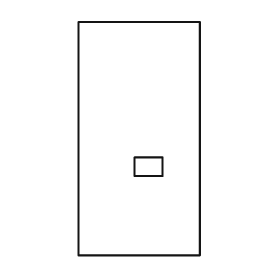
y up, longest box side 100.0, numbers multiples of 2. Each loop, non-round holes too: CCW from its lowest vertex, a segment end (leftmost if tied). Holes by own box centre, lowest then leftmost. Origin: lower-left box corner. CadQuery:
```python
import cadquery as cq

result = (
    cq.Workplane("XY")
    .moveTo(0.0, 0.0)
    .lineTo(52.0, 0.0)
    .lineTo(52.0, 100.0)
    .lineTo(0.0, 100.0)
    .close()
    .moveTo(24.0, 34.0)
    .lineTo(36.0, 34.0)
    .lineTo(36.0, 42.0)
    .lineTo(24.0, 42.0)
    .close()
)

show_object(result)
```